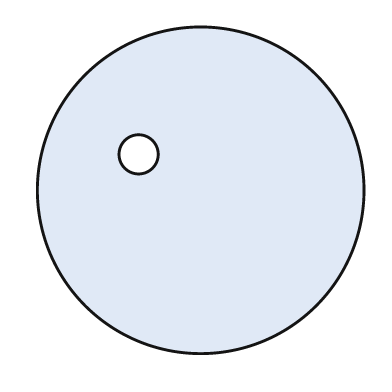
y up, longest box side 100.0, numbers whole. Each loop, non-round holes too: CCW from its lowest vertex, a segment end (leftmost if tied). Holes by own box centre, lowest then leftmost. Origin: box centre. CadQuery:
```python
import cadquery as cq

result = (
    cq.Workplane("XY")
    .moveTo(0.0, 0.0)
    .circle(50.0)
    .moveTo(-19.0, 11.0)
    .circle(6.0)
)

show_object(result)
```